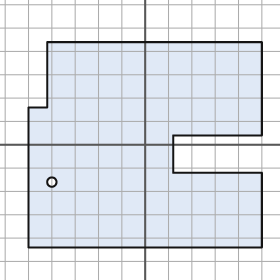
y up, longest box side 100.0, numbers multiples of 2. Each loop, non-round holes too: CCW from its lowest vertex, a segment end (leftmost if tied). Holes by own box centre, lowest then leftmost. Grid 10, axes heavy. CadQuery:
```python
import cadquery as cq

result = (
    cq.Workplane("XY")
    .moveTo(-50.0, -44.0)
    .lineTo(50.0, -44.0)
    .lineTo(50.0, -12.0)
    .lineTo(12.0, -12.0)
    .lineTo(12.0, 4.0)
    .lineTo(50.0, 4.0)
    .lineTo(50.0, 44.0)
    .lineTo(-42.0, 44.0)
    .lineTo(-42.0, 16.0)
    .lineTo(-50.0, 16.0)
    .close()
    .moveTo(-40.0, -16.0)
    .circle(2.0)
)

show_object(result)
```